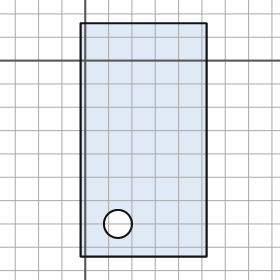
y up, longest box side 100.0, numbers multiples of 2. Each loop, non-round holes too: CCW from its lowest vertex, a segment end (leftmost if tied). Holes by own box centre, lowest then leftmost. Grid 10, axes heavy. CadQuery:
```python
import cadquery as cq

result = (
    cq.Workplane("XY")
    .moveTo(-2.0, -84.0)
    .lineTo(52.0, -84.0)
    .lineTo(52.0, 16.0)
    .lineTo(-2.0, 16.0)
    .close()
    .moveTo(14.0, -70.0)
    .circle(6.0)
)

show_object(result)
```